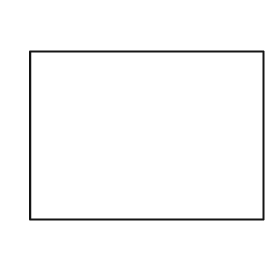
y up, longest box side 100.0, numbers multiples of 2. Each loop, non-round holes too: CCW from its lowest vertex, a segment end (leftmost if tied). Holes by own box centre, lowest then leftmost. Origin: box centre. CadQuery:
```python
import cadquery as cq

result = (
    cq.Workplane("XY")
    .moveTo(-50.0, -36.0)
    .lineTo(50.0, -36.0)
    .lineTo(50.0, 36.0)
    .lineTo(-50.0, 36.0)
    .close()
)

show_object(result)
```